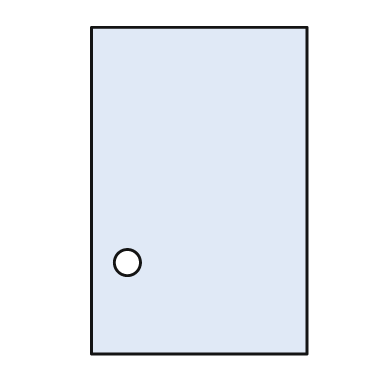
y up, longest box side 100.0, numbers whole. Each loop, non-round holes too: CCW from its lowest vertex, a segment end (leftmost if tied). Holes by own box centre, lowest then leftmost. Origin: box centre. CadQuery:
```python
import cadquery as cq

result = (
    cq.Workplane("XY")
    .moveTo(-33.0, -50.0)
    .lineTo(33.0, -50.0)
    .lineTo(33.0, 50.0)
    .lineTo(-33.0, 50.0)
    .close()
    .moveTo(-22.0, -22.0)
    .circle(4.0)
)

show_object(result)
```